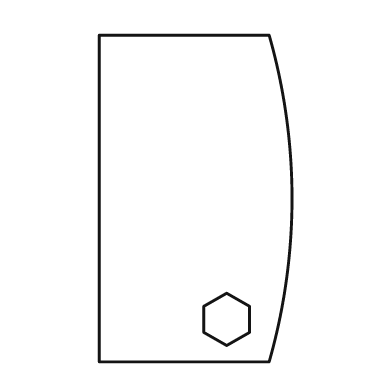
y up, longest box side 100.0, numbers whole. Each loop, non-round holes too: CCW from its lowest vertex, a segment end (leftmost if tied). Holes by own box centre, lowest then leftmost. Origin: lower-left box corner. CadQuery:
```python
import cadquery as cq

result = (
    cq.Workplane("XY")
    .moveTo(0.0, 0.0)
    .lineTo(52.0, 0.0)
    .threePointArc((59.0, 50.0), (52.0, 100.0))
    .lineTo(0.0, 100.0)
    .close()
    .moveTo(39.0, 5.0)
    .lineTo(46.0, 9.0)
    .lineTo(46.0, 17.0)
    .lineTo(39.0, 21.0)
    .lineTo(32.0, 17.0)
    .lineTo(32.0, 9.0)
    .close()
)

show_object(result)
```